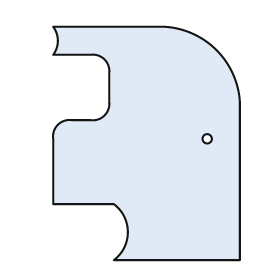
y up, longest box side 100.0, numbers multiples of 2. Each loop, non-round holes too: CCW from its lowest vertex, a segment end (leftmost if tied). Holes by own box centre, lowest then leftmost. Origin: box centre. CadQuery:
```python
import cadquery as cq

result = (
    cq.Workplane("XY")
    .moveTo(-14.0, -50.0)
    .lineTo(40.0, -50.0)
    .lineTo(40.0, 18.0)
    .threePointArc((30.0, 40.0), (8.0, 50.0))
    .lineTo(-40.0, 50.0)
    .threePointArc((-38.0, 44.0), (-40.0, 38.0))
    .lineTo(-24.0, 38.0)
    .threePointArc((-18.0, 36.0), (-16.0, 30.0))
    .lineTo(-16.0, 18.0)
    .threePointArc((-18.0, 12.0), (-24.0, 10.0))
    .lineTo(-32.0, 10.0)
    .threePointArc((-38.0, 8.0), (-40.0, 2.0))
    .lineTo(-40.0, -26.0)
    .lineTo(-14.0, -26.0)
    .threePointArc((-8.0, -38.0), (-14.0, -50.0))
    .close()
    .moveTo(26.0, 2.0)
    .circle(2.0)
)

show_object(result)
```